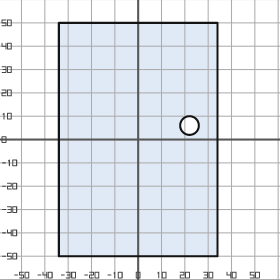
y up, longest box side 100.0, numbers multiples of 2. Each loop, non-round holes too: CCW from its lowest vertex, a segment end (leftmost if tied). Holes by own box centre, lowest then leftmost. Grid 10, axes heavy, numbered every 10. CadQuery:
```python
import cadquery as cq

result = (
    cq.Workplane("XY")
    .moveTo(-34.0, -50.0)
    .lineTo(34.0, -50.0)
    .lineTo(34.0, 50.0)
    .lineTo(-34.0, 50.0)
    .close()
    .moveTo(22.0, 6.0)
    .circle(4.0)
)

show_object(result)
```